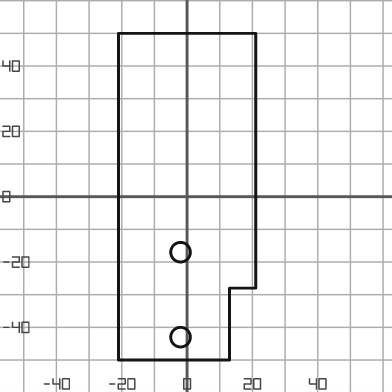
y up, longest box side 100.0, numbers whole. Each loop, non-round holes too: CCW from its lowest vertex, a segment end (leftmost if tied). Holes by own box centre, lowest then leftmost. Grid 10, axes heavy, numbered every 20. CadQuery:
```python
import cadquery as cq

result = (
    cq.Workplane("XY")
    .moveTo(-21.0, -50.0)
    .lineTo(13.0, -50.0)
    .lineTo(13.0, -28.0)
    .lineTo(21.0, -28.0)
    .lineTo(21.0, 50.0)
    .lineTo(-21.0, 50.0)
    .close()
    .moveTo(-2.0, -43.0)
    .circle(3.0)
    .moveTo(-2.0, -17.0)
    .circle(3.0)
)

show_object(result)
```